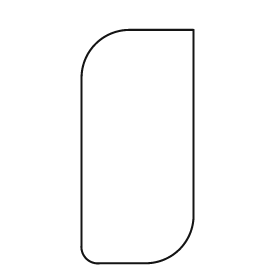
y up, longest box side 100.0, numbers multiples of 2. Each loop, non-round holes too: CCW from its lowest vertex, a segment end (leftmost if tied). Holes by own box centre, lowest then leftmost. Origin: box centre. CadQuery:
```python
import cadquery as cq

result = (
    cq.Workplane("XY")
    .moveTo(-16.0, -50.0)
    .lineTo(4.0, -50.0)
    .threePointArc((18.0, -44.0), (24.0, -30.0))
    .lineTo(24.0, 50.0)
    .lineTo(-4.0, 50.0)
    .threePointArc((-18.0, 44.0), (-24.0, 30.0))
    .lineTo(-24.0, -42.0)
    .threePointArc((-22.0, -48.0), (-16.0, -50.0))
    .close()
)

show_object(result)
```